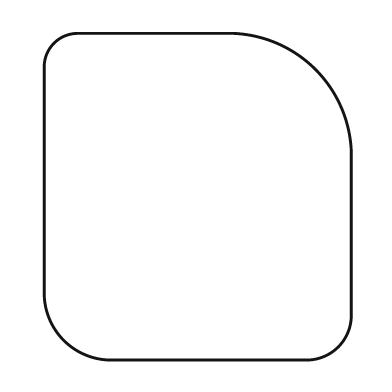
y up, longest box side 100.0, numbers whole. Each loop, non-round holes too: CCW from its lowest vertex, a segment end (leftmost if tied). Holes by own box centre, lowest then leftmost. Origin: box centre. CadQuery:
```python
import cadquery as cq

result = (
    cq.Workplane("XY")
    .moveTo(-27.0, -50.0)
    .lineTo(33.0, -50.0)
    .threePointArc((43.0, -46.0), (47.0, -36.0))
    .lineTo(47.0, 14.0)
    .threePointArc((36.0, 39.0), (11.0, 50.0))
    .lineTo(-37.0, 50.0)
    .threePointArc((-44.0, 47.0), (-47.0, 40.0))
    .lineTo(-47.0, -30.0)
    .threePointArc((-41.0, -44.0), (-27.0, -50.0))
    .close()
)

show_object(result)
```